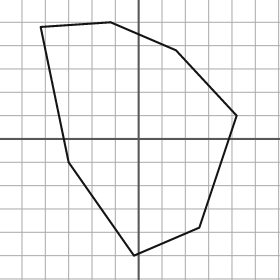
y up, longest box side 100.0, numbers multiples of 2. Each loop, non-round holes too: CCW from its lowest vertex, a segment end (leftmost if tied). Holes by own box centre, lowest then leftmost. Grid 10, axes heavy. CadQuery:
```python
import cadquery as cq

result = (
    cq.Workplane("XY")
    .moveTo(-2.0, -50.0)
    .lineTo(26.0, -38.0)
    .lineTo(42.0, 10.0)
    .lineTo(16.0, 38.0)
    .lineTo(-12.0, 50.0)
    .lineTo(-42.0, 48.0)
    .lineTo(-30.0, -10.0)
    .close()
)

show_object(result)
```